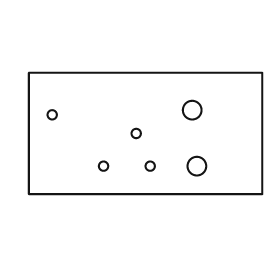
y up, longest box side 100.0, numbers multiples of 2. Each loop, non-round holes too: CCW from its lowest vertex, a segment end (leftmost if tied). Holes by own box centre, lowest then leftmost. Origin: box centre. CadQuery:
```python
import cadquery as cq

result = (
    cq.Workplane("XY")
    .moveTo(-50.0, -26.0)
    .lineTo(50.0, -26.0)
    .lineTo(50.0, 26.0)
    .lineTo(-50.0, 26.0)
    .close()
    .moveTo(-18.0, -14.0)
    .circle(2.0)
    .moveTo(2.0, -14.0)
    .circle(2.0)
    .moveTo(22.0, -14.0)
    .circle(4.0)
    .moveTo(-4.0, 0.0)
    .circle(2.0)
    .moveTo(-40.0, 8.0)
    .circle(2.0)
    .moveTo(20.0, 10.0)
    .circle(4.0)
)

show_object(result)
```